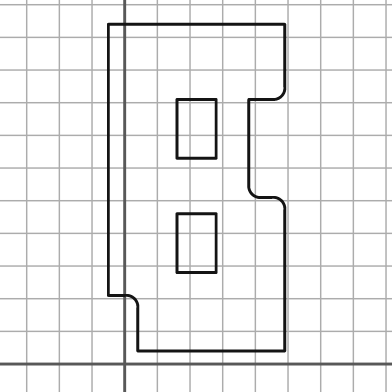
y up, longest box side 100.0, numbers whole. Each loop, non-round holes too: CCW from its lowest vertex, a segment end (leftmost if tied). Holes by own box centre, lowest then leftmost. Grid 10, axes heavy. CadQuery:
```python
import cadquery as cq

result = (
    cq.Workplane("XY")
    .moveTo(4.0, 4.0)
    .lineTo(49.0, 4.0)
    .lineTo(49.0, 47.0)
    .threePointArc((48.0, 50.0), (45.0, 51.0))
    .lineTo(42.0, 51.0)
    .threePointArc((39.0, 52.0), (38.0, 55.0))
    .lineTo(38.0, 81.0)
    .lineTo(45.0, 81.0)
    .threePointArc((48.0, 82.0), (49.0, 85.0))
    .lineTo(49.0, 104.0)
    .lineTo(-5.0, 104.0)
    .lineTo(-5.0, 21.0)
    .lineTo(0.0, 21.0)
    .threePointArc((3.0, 20.0), (4.0, 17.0))
    .close()
    .moveTo(16.0, 28.0)
    .lineTo(28.0, 28.0)
    .lineTo(28.0, 46.0)
    .lineTo(16.0, 46.0)
    .close()
    .moveTo(16.0, 63.0)
    .lineTo(28.0, 63.0)
    .lineTo(28.0, 81.0)
    .lineTo(16.0, 81.0)
    .close()
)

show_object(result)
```